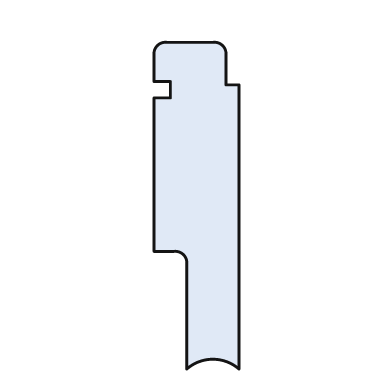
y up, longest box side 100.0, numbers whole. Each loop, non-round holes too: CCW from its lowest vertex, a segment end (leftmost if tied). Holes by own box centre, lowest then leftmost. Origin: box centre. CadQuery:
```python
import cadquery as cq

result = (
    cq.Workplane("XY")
    .moveTo(-3.0, -50.0)
    .threePointArc((5.0, -47.0), (13.0, -50.0))
    .lineTo(13.0, 37.0)
    .lineTo(9.0, 37.0)
    .lineTo(9.0, 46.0)
    .threePointArc((8.0, 49.0), (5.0, 50.0))
    .lineTo(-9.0, 50.0)
    .threePointArc((-12.0, 49.0), (-13.0, 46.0))
    .lineTo(-13.0, 38.0)
    .lineTo(-8.0, 38.0)
    .lineTo(-8.0, 33.0)
    .lineTo(-13.0, 33.0)
    .lineTo(-13.0, -14.0)
    .lineTo(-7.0, -14.0)
    .threePointArc((-4.0, -15.0), (-3.0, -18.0))
    .close()
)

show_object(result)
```